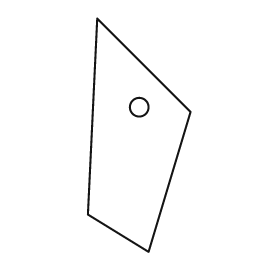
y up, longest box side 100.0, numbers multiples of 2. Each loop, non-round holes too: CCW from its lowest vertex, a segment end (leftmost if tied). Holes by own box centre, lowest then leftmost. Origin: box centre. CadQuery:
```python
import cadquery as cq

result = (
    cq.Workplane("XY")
    .moveTo(4.0, -50.0)
    .lineTo(22.0, 10.0)
    .lineTo(-18.0, 50.0)
    .lineTo(-22.0, -34.0)
    .close()
    .moveTo(0.0, 12.0)
    .circle(4.0)
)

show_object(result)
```